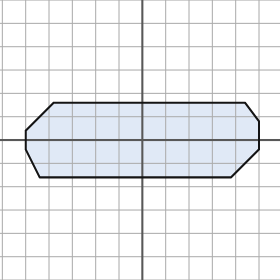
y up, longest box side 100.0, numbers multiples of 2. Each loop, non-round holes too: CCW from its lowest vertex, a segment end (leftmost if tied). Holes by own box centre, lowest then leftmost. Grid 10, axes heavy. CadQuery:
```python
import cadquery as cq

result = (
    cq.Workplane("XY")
    .moveTo(-44.0, -16.0)
    .lineTo(38.0, -16.0)
    .lineTo(50.0, -4.0)
    .lineTo(50.0, 8.0)
    .lineTo(44.0, 16.0)
    .lineTo(-38.0, 16.0)
    .lineTo(-50.0, 4.0)
    .lineTo(-50.0, -4.0)
    .close()
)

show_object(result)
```